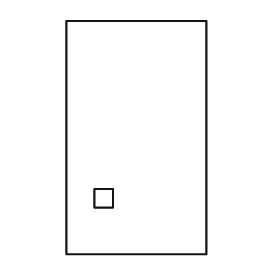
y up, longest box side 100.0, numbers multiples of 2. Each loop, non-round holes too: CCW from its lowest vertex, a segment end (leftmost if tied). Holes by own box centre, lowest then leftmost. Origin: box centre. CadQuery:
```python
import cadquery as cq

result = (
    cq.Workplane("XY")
    .moveTo(-30.0, -50.0)
    .lineTo(30.0, -50.0)
    .lineTo(30.0, 50.0)
    .lineTo(-30.0, 50.0)
    .close()
    .moveTo(-18.0, -30.0)
    .lineTo(-10.0, -30.0)
    .lineTo(-10.0, -22.0)
    .lineTo(-18.0, -22.0)
    .close()
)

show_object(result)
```